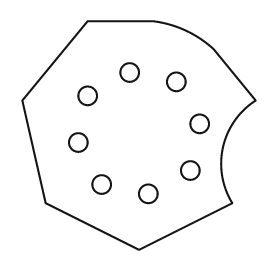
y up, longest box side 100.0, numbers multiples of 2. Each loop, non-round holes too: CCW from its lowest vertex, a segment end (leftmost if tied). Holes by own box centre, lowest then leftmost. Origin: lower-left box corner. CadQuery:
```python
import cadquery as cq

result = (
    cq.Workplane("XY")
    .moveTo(50.0, 0.0)
    .lineTo(90.0, 20.0)
    .threePointArc((86.0, 44.0), (100.0, 64.0))
    .lineTo(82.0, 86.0)
    .threePointArc((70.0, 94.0), (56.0, 98.0))
    .lineTo(28.0, 98.0)
    .lineTo(0.0, 64.0)
    .lineTo(10.0, 20.0)
    .close()
    .moveTo(54.0, 24.0)
    .circle(4.0)
    .moveTo(34.0, 28.0)
    .circle(4.0)
    .moveTo(72.0, 34.0)
    .circle(4.0)
    .moveTo(24.0, 46.0)
    .circle(4.0)
    .moveTo(76.0, 54.0)
    .circle(4.0)
    .moveTo(28.0, 66.0)
    .circle(4.0)
    .moveTo(66.0, 72.0)
    .circle(4.0)
    .moveTo(46.0, 76.0)
    .circle(4.0)
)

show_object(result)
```